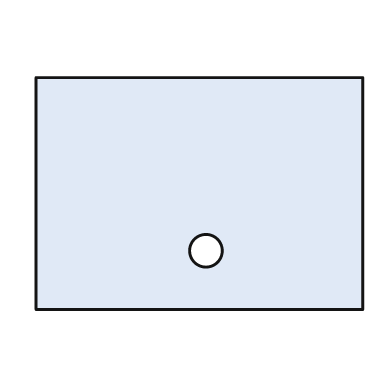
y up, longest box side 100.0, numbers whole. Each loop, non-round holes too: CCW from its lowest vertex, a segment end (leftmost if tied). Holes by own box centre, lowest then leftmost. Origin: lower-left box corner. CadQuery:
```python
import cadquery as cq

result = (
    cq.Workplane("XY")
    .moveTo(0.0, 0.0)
    .lineTo(100.0, 0.0)
    .lineTo(100.0, 71.0)
    .lineTo(0.0, 71.0)
    .close()
    .moveTo(52.0, 18.0)
    .circle(5.0)
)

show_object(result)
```